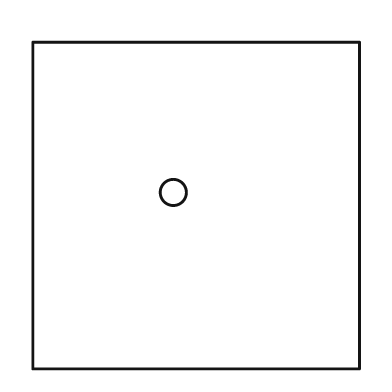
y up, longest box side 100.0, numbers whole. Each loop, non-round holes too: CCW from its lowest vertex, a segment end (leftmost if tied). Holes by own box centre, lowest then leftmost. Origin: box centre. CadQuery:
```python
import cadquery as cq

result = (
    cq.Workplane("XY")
    .moveTo(-50.0, -50.0)
    .lineTo(50.0, -50.0)
    .lineTo(50.0, 50.0)
    .lineTo(-50.0, 50.0)
    .close()
    .moveTo(-7.0, 4.0)
    .circle(4.0)
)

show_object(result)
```